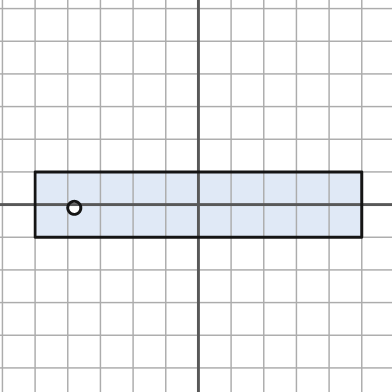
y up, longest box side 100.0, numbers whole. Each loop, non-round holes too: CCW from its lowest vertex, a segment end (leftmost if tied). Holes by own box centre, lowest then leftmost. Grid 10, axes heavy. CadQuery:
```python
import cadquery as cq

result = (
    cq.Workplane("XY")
    .moveTo(-50.0, -10.0)
    .lineTo(50.0, -10.0)
    .lineTo(50.0, 10.0)
    .lineTo(-50.0, 10.0)
    .close()
    .moveTo(-38.0, -1.0)
    .circle(2.0)
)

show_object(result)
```